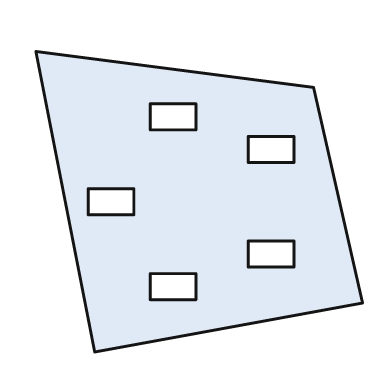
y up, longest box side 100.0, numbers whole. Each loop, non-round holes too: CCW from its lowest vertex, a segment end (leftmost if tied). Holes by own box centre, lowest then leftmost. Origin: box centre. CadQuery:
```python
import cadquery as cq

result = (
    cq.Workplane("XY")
    .moveTo(-32.0, -46.0)
    .lineTo(50.0, -31.0)
    .lineTo(35.0, 35.0)
    .lineTo(-50.0, 46.0)
    .close()
    .moveTo(-15.0, -30.0)
    .lineTo(-1.0, -30.0)
    .lineTo(-1.0, -22.0)
    .lineTo(-15.0, -22.0)
    .close()
    .moveTo(15.0, -20.0)
    .lineTo(29.0, -20.0)
    .lineTo(29.0, -12.0)
    .lineTo(15.0, -12.0)
    .close()
    .moveTo(-34.0, -4.0)
    .lineTo(-20.0, -4.0)
    .lineTo(-20.0, 4.0)
    .lineTo(-34.0, 4.0)
    .close()
    .moveTo(15.0, 12.0)
    .lineTo(29.0, 12.0)
    .lineTo(29.0, 20.0)
    .lineTo(15.0, 20.0)
    .close()
    .moveTo(-15.0, 22.0)
    .lineTo(-1.0, 22.0)
    .lineTo(-1.0, 30.0)
    .lineTo(-15.0, 30.0)
    .close()
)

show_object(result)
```